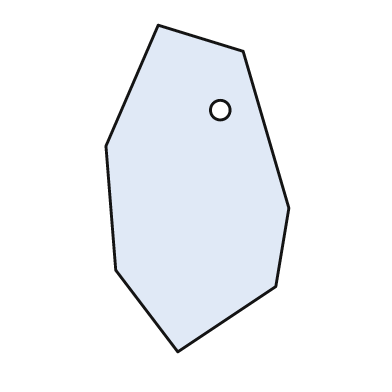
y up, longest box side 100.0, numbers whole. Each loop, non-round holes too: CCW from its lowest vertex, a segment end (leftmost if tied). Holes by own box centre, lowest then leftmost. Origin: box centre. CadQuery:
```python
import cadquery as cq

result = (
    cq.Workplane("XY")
    .moveTo(-6.0, -50.0)
    .lineTo(24.0, -30.0)
    .lineTo(28.0, -6.0)
    .lineTo(14.0, 42.0)
    .lineTo(-12.0, 50.0)
    .lineTo(-28.0, 13.0)
    .lineTo(-25.0, -25.0)
    .close()
    .moveTo(7.0, 24.0)
    .circle(3.0)
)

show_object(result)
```